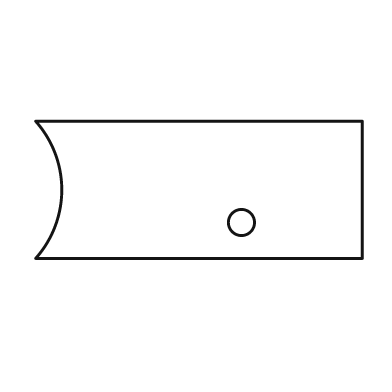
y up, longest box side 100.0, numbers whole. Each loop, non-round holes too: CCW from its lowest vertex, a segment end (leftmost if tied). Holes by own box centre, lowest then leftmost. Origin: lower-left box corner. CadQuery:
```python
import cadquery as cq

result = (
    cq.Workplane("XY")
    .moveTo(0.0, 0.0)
    .lineTo(100.0, 0.0)
    .lineTo(100.0, 42.0)
    .lineTo(0.0, 42.0)
    .threePointArc((8.0, 21.0), (0.0, 0.0))
    .close()
    .moveTo(63.0, 11.0)
    .circle(4.0)
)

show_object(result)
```